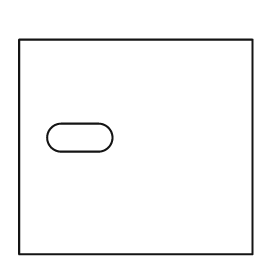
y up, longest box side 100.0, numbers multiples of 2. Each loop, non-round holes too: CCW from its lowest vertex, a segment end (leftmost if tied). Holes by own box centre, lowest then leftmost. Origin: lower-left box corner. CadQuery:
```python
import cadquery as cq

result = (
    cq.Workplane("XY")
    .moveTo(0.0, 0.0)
    .lineTo(100.0, 0.0)
    .lineTo(100.0, 92.0)
    .lineTo(0.0, 92.0)
    .close()
    .moveTo(18.0, 44.0)
    .lineTo(34.0, 44.0)
    .threePointArc((40.0, 50.0), (34.0, 56.0))
    .lineTo(18.0, 56.0)
    .threePointArc((12.0, 50.0), (18.0, 44.0))
    .close()
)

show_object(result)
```